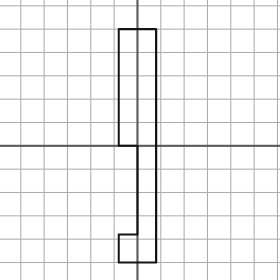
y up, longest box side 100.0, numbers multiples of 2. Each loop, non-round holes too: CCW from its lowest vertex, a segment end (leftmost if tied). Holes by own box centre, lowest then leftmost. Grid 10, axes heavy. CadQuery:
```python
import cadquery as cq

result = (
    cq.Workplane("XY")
    .moveTo(-8.0, -50.0)
    .lineTo(8.0, -50.0)
    .lineTo(8.0, 50.0)
    .lineTo(-8.0, 50.0)
    .lineTo(-8.0, 0.0)
    .lineTo(0.0, 0.0)
    .lineTo(0.0, -38.0)
    .lineTo(-8.0, -38.0)
    .close()
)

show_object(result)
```